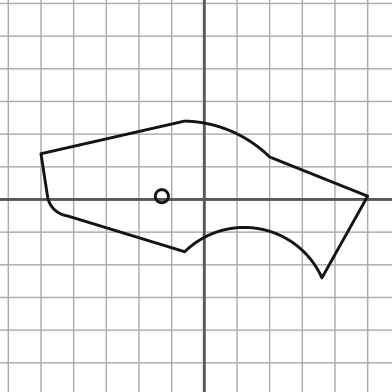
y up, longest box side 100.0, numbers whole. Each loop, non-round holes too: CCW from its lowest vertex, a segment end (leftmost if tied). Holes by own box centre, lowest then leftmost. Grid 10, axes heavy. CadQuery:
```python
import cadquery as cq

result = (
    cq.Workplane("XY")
    .moveTo(36.0, -24.0)
    .lineTo(50.0, 1.0)
    .lineTo(20.0, 13.0)
    .threePointArc((8.0, 21.0), (-6.0, 24.0))
    .lineTo(-50.0, 14.0)
    .lineTo(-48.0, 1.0)
    .threePointArc((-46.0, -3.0), (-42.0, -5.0))
    .lineTo(-6.0, -16.0)
    .threePointArc((17.0, -9.0), (36.0, -24.0))
    .close()
    .moveTo(-13.0, 1.0)
    .circle(2.0)
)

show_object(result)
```